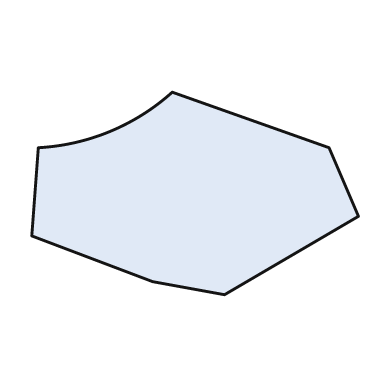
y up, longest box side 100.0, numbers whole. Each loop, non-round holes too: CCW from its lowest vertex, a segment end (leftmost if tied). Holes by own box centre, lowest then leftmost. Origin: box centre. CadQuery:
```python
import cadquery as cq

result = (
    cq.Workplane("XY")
    .moveTo(9.0, -31.0)
    .lineTo(50.0, -7.0)
    .lineTo(41.0, 14.0)
    .lineTo(-7.0, 31.0)
    .threePointArc((-26.0, 19.0), (-48.0, 14.0))
    .lineTo(-50.0, -13.0)
    .lineTo(-13.0, -27.0)
    .close()
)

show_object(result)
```